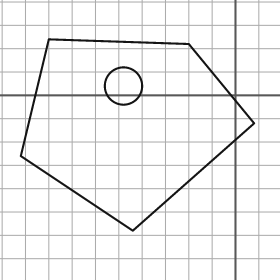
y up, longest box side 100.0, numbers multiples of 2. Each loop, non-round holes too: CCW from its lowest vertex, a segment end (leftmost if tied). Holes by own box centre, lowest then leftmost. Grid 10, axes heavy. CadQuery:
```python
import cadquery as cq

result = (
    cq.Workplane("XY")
    .moveTo(-44.0, -58.0)
    .lineTo(8.0, -12.0)
    .lineTo(-20.0, 22.0)
    .lineTo(-80.0, 24.0)
    .lineTo(-92.0, -26.0)
    .close()
    .moveTo(-48.0, 4.0)
    .circle(8.0)
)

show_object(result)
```